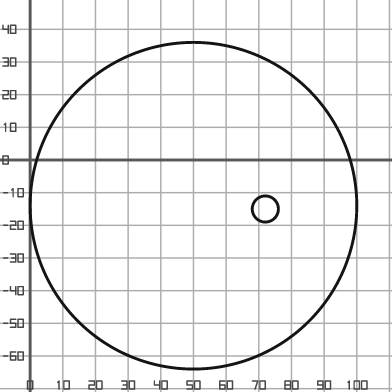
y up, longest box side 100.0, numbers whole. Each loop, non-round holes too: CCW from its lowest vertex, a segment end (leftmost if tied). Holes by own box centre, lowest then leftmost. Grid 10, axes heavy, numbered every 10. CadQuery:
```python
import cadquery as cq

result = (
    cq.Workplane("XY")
    .moveTo(50.0, -14.0)
    .circle(50.0)
    .moveTo(72.0, -15.0)
    .circle(4.0)
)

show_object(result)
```